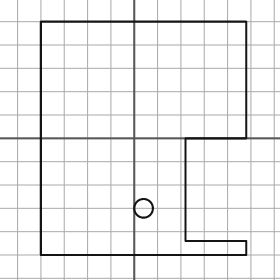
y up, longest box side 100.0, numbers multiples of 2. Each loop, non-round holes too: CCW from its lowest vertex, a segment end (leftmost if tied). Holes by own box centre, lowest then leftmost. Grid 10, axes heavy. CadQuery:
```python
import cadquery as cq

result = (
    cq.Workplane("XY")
    .moveTo(-40.0, -50.0)
    .lineTo(48.0, -50.0)
    .lineTo(48.0, -44.0)
    .lineTo(22.0, -44.0)
    .lineTo(22.0, 0.0)
    .lineTo(48.0, 0.0)
    .lineTo(48.0, 50.0)
    .lineTo(-40.0, 50.0)
    .close()
    .moveTo(4.0, -30.0)
    .circle(4.0)
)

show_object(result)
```